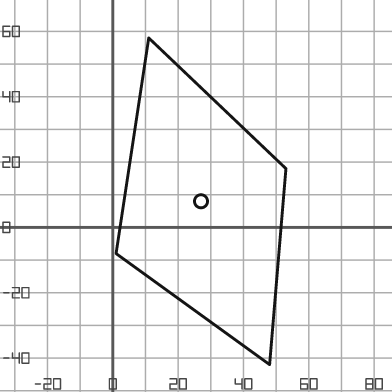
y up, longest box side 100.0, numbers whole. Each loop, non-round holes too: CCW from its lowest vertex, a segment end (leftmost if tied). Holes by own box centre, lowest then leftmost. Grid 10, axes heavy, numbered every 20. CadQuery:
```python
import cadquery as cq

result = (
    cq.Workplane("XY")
    .moveTo(48.0, -42.0)
    .lineTo(53.0, 18.0)
    .lineTo(11.0, 58.0)
    .lineTo(1.0, -8.0)
    .close()
    .moveTo(27.0, 8.0)
    .circle(2.0)
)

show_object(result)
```